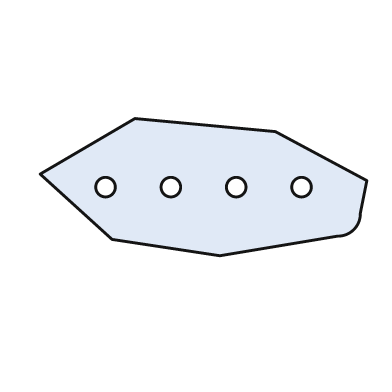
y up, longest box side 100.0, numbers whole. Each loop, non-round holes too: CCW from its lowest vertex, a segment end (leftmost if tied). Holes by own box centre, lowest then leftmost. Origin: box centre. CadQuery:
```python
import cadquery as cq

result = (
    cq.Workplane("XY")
    .moveTo(5.0, -21.0)
    .lineTo(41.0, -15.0)
    .threePointArc((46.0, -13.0), (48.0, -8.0))
    .lineTo(50.0, 2.0)
    .lineTo(22.0, 17.0)
    .lineTo(-21.0, 21.0)
    .lineTo(-50.0, 4.0)
    .lineTo(-28.0, -16.0)
    .close()
    .moveTo(-30.0, 0.0)
    .circle(3.0)
    .moveTo(-10.0, 0.0)
    .circle(3.0)
    .moveTo(10.0, 0.0)
    .circle(3.0)
    .moveTo(30.0, 0.0)
    .circle(3.0)
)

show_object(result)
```